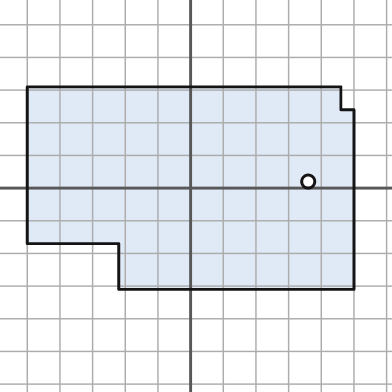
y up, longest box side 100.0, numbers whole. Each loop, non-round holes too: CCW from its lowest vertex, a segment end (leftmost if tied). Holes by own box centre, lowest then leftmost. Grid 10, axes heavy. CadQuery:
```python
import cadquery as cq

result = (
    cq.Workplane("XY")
    .moveTo(-22.0, -31.0)
    .lineTo(50.0, -31.0)
    .lineTo(50.0, 24.0)
    .lineTo(46.0, 24.0)
    .lineTo(46.0, 31.0)
    .lineTo(-50.0, 31.0)
    .lineTo(-50.0, -17.0)
    .lineTo(-22.0, -17.0)
    .close()
    .moveTo(36.0, 2.0)
    .circle(2.0)
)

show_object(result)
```